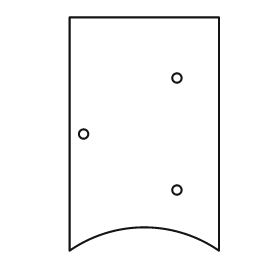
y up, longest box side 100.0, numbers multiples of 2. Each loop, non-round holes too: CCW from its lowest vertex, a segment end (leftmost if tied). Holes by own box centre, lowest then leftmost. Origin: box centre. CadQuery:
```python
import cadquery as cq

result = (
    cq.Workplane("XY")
    .moveTo(-32.0, -50.0)
    .threePointArc((0.0, -40.0), (32.0, -50.0))
    .lineTo(32.0, 50.0)
    .lineTo(-32.0, 50.0)
    .close()
    .moveTo(14.0, -24.0)
    .circle(2.0)
    .moveTo(-26.0, 0.0)
    .circle(2.0)
    .moveTo(14.0, 24.0)
    .circle(2.0)
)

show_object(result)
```